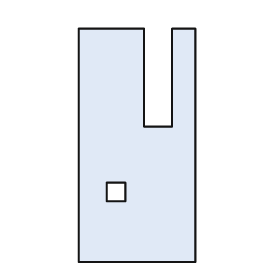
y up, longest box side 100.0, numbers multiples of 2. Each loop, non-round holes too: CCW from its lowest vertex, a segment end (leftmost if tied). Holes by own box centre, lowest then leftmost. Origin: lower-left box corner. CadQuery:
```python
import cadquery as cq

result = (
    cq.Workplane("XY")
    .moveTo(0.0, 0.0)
    .lineTo(50.0, 0.0)
    .lineTo(50.0, 100.0)
    .lineTo(40.0, 100.0)
    .lineTo(40.0, 58.0)
    .lineTo(28.0, 58.0)
    .lineTo(28.0, 100.0)
    .lineTo(0.0, 100.0)
    .close()
    .moveTo(12.0, 26.0)
    .lineTo(20.0, 26.0)
    .lineTo(20.0, 34.0)
    .lineTo(12.0, 34.0)
    .close()
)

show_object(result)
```